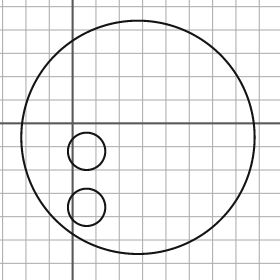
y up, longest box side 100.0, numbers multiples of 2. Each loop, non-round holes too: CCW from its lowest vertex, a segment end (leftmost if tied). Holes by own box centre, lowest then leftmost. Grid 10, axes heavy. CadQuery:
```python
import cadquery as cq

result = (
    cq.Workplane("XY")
    .moveTo(28.0, -6.0)
    .circle(50.0)
    .moveTo(6.0, -36.0)
    .circle(8.0)
    .moveTo(6.0, -12.0)
    .circle(8.0)
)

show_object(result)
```